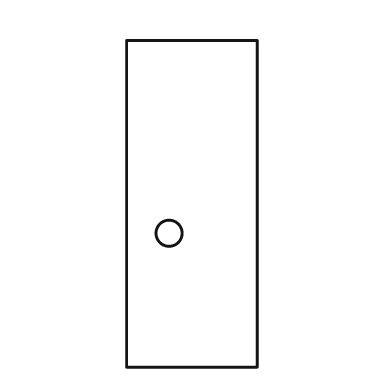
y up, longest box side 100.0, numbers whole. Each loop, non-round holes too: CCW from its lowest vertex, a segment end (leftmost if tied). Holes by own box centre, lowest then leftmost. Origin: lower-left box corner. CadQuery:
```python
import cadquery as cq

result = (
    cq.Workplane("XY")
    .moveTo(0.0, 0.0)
    .lineTo(40.0, 0.0)
    .lineTo(40.0, 100.0)
    .lineTo(0.0, 100.0)
    .close()
    .moveTo(13.0, 41.0)
    .circle(4.0)
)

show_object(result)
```